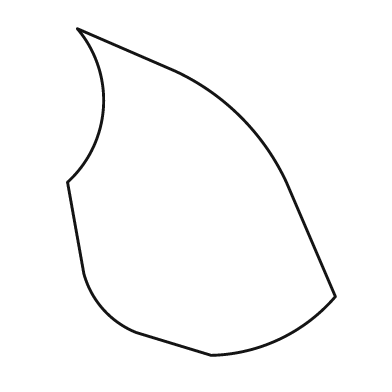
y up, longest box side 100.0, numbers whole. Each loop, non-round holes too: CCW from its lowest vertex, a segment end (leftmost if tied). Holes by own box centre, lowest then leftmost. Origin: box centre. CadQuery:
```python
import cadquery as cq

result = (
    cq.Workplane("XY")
    .moveTo(3.0, -50.0)
    .threePointArc((24.0, -45.0), (41.0, -32.0))
    .lineTo(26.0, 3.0)
    .threePointArc((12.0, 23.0), (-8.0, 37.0))
    .lineTo(-38.0, 50.0)
    .threePointArc((-30.0, 26.0), (-41.0, 3.0))
    .lineTo(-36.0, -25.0)
    .threePointArc((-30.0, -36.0), (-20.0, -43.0))
    .close()
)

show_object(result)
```